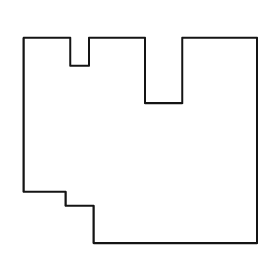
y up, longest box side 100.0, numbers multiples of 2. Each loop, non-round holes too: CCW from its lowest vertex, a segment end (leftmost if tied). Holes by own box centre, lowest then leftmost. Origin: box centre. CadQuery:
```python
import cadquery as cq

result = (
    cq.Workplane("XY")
    .moveTo(-20.0, -44.0)
    .lineTo(50.0, -44.0)
    .lineTo(50.0, 44.0)
    .lineTo(18.0, 44.0)
    .lineTo(18.0, 16.0)
    .lineTo(2.0, 16.0)
    .lineTo(2.0, 44.0)
    .lineTo(-22.0, 44.0)
    .lineTo(-22.0, 32.0)
    .lineTo(-30.0, 32.0)
    .lineTo(-30.0, 44.0)
    .lineTo(-50.0, 44.0)
    .lineTo(-50.0, -22.0)
    .lineTo(-32.0, -22.0)
    .lineTo(-32.0, -28.0)
    .lineTo(-20.0, -28.0)
    .close()
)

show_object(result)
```